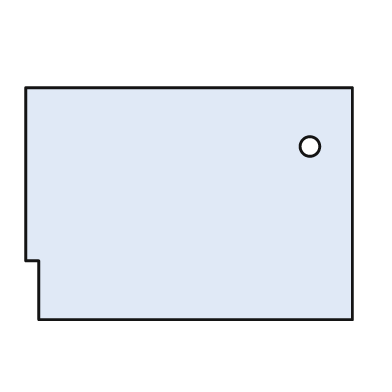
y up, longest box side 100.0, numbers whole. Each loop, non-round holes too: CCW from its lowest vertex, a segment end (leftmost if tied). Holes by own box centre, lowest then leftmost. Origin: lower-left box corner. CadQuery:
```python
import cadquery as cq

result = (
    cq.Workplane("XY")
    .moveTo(4.0, 0.0)
    .lineTo(100.0, 0.0)
    .lineTo(100.0, 71.0)
    .lineTo(0.0, 71.0)
    .lineTo(0.0, 18.0)
    .lineTo(4.0, 18.0)
    .close()
    .moveTo(87.0, 53.0)
    .circle(3.0)
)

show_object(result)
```